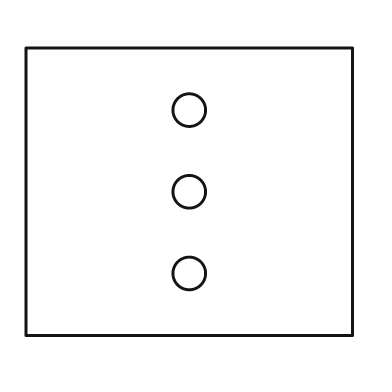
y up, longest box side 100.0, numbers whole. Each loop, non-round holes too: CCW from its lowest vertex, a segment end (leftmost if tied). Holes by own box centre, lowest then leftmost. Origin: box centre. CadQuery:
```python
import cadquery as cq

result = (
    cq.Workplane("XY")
    .moveTo(-50.0, -44.0)
    .lineTo(50.0, -44.0)
    .lineTo(50.0, 44.0)
    .lineTo(-50.0, 44.0)
    .close()
    .moveTo(0.0, -25.0)
    .circle(5.0)
    .moveTo(0.0, 0.0)
    .circle(5.0)
    .moveTo(0.0, 25.0)
    .circle(5.0)
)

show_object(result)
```